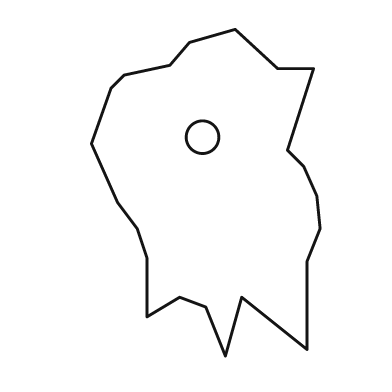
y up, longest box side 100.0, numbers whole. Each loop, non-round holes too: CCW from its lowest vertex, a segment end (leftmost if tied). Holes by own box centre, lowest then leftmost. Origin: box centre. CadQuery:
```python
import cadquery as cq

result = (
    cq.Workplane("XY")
    .moveTo(6.0, -50.0)
    .lineTo(11.0, -32.0)
    .lineTo(31.0, -48.0)
    .lineTo(31.0, -21.0)
    .lineTo(35.0, -11.0)
    .lineTo(34.0, -1.0)
    .lineTo(30.0, 8.0)
    .lineTo(25.0, 13.0)
    .lineTo(33.0, 38.0)
    .lineTo(22.0, 38.0)
    .lineTo(9.0, 50.0)
    .lineTo(-5.0, 46.0)
    .lineTo(-11.0, 39.0)
    .lineTo(-25.0, 36.0)
    .lineTo(-29.0, 32.0)
    .lineTo(-35.0, 15.0)
    .lineTo(-27.0, -3.0)
    .lineTo(-21.0, -11.0)
    .lineTo(-18.0, -20.0)
    .lineTo(-18.0, -38.0)
    .lineTo(-8.0, -32.0)
    .lineTo(0.0, -35.0)
    .close()
    .moveTo(-1.0, 17.0)
    .circle(5.0)
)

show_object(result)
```